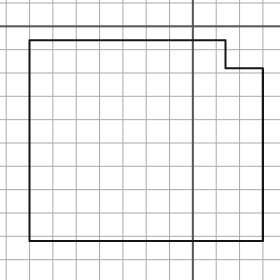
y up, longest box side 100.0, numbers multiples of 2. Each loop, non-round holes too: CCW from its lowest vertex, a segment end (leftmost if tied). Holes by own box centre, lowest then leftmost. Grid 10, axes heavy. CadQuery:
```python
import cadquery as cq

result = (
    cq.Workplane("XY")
    .moveTo(-70.0, -92.0)
    .lineTo(30.0, -92.0)
    .lineTo(30.0, -18.0)
    .lineTo(14.0, -18.0)
    .lineTo(14.0, -6.0)
    .lineTo(-70.0, -6.0)
    .close()
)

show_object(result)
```